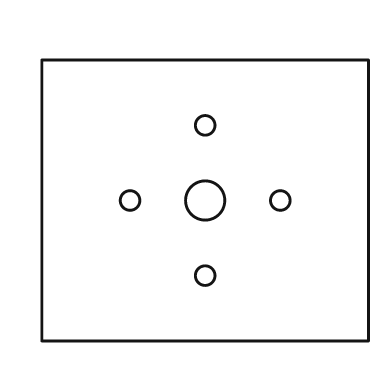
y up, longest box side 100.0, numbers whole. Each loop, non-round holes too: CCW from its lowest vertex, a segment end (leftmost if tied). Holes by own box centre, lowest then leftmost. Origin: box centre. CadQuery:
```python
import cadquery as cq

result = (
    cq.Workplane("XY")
    .moveTo(-50.0, -43.0)
    .lineTo(50.0, -43.0)
    .lineTo(50.0, 43.0)
    .lineTo(-50.0, 43.0)
    .close()
    .moveTo(0.0, -23.0)
    .circle(3.0)
    .moveTo(-23.0, 0.0)
    .circle(3.0)
    .moveTo(0.0, 0.0)
    .circle(6.0)
    .moveTo(23.0, 0.0)
    .circle(3.0)
    .moveTo(0.0, 23.0)
    .circle(3.0)
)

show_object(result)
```